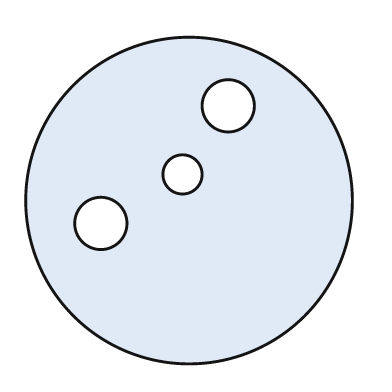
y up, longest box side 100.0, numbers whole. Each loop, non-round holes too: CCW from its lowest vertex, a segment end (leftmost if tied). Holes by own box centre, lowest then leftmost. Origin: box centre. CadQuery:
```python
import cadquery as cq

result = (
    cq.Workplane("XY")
    .moveTo(0.0, 0.0)
    .circle(50.0)
    .moveTo(-27.0, -7.0)
    .circle(8.0)
    .moveTo(-2.0, 8.0)
    .circle(6.0)
    .moveTo(12.0, 29.0)
    .circle(8.0)
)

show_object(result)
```